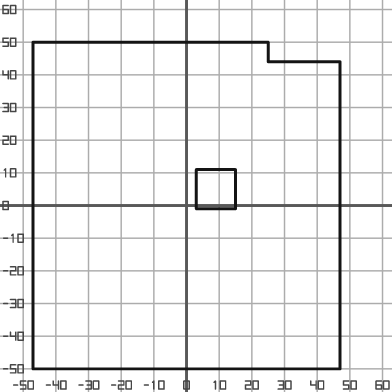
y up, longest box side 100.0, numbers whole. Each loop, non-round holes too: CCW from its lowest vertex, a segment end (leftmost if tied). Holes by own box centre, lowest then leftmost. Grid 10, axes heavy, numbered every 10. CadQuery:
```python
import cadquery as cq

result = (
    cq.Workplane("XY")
    .moveTo(-47.0, -50.0)
    .lineTo(47.0, -50.0)
    .lineTo(47.0, 44.0)
    .lineTo(25.0, 44.0)
    .lineTo(25.0, 50.0)
    .lineTo(-47.0, 50.0)
    .close()
    .moveTo(3.0, -1.0)
    .lineTo(15.0, -1.0)
    .lineTo(15.0, 11.0)
    .lineTo(3.0, 11.0)
    .close()
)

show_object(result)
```